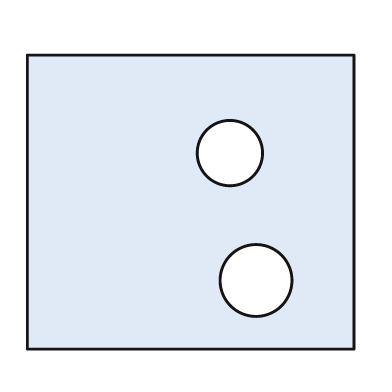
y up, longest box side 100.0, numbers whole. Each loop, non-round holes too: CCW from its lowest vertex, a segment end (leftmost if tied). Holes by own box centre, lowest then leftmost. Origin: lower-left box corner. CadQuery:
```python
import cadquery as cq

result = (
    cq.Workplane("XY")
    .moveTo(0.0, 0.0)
    .lineTo(100.0, 0.0)
    .lineTo(100.0, 90.0)
    .lineTo(0.0, 90.0)
    .close()
    .moveTo(70.0, 21.0)
    .circle(11.0)
    .moveTo(62.0, 60.0)
    .circle(10.0)
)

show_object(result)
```